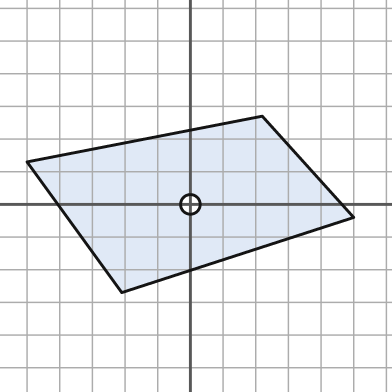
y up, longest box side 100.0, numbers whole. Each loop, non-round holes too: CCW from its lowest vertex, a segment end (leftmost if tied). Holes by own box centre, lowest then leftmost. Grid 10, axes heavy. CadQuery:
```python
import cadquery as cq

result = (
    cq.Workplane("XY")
    .moveTo(-21.0, -27.0)
    .lineTo(50.0, -4.0)
    .lineTo(22.0, 27.0)
    .lineTo(-50.0, 13.0)
    .close()
    .moveTo(0.0, 0.0)
    .circle(3.0)
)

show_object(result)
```